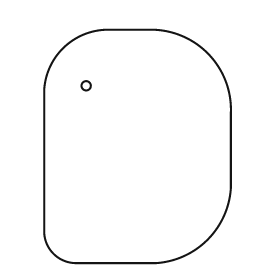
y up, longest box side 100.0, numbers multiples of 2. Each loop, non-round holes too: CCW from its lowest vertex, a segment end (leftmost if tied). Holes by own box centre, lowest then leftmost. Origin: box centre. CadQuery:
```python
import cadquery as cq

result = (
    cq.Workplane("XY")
    .moveTo(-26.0, -50.0)
    .lineTo(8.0, -50.0)
    .threePointArc((30.0, -40.0), (40.0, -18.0))
    .lineTo(40.0, 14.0)
    .threePointArc((30.0, 40.0), (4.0, 50.0))
    .lineTo(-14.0, 50.0)
    .threePointArc((-32.0, 42.0), (-40.0, 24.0))
    .lineTo(-40.0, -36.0)
    .threePointArc((-36.0, -46.0), (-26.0, -50.0))
    .close()
    .moveTo(-22.0, 26.0)
    .circle(2.0)
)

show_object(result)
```